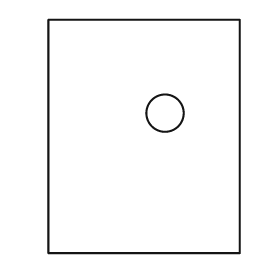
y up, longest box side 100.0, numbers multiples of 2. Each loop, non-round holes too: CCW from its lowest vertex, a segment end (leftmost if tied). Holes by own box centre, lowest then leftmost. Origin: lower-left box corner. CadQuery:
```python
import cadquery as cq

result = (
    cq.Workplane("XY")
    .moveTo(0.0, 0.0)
    .lineTo(82.0, 0.0)
    .lineTo(82.0, 100.0)
    .lineTo(0.0, 100.0)
    .close()
    .moveTo(50.0, 60.0)
    .circle(8.0)
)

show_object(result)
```